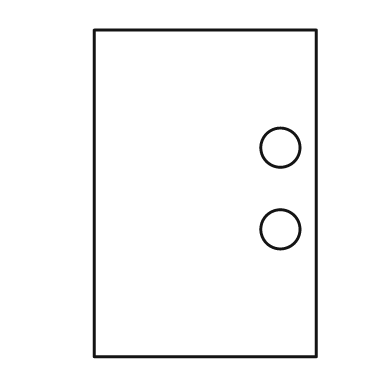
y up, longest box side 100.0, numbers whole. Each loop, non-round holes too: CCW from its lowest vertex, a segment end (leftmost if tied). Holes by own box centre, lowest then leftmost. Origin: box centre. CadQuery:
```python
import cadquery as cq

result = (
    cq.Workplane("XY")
    .moveTo(-34.0, -50.0)
    .lineTo(34.0, -50.0)
    .lineTo(34.0, 50.0)
    .lineTo(-34.0, 50.0)
    .close()
    .moveTo(23.0, -11.0)
    .circle(6.0)
    .moveTo(23.0, 14.0)
    .circle(6.0)
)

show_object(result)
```